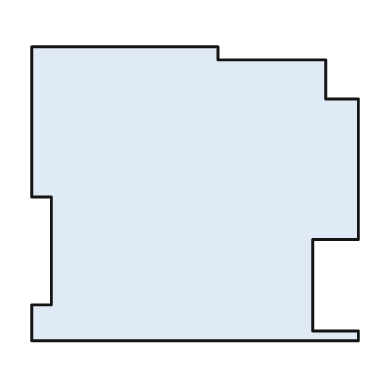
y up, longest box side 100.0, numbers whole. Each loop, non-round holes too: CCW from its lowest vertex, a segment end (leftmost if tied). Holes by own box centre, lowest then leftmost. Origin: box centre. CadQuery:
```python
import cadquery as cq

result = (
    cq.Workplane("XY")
    .moveTo(-50.0, -45.0)
    .lineTo(50.0, -45.0)
    .lineTo(50.0, -42.0)
    .lineTo(36.0, -42.0)
    .lineTo(36.0, -14.0)
    .lineTo(50.0, -14.0)
    .lineTo(50.0, 29.0)
    .lineTo(40.0, 29.0)
    .lineTo(40.0, 41.0)
    .lineTo(7.0, 41.0)
    .lineTo(7.0, 45.0)
    .lineTo(-50.0, 45.0)
    .lineTo(-50.0, -1.0)
    .lineTo(-44.0, -1.0)
    .lineTo(-44.0, -34.0)
    .lineTo(-50.0, -34.0)
    .close()
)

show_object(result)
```